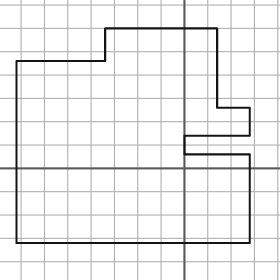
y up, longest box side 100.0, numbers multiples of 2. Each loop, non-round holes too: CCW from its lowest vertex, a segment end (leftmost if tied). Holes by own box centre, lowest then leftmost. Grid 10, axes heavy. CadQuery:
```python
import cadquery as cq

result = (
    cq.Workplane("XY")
    .moveTo(-72.0, -32.0)
    .lineTo(28.0, -32.0)
    .lineTo(28.0, 6.0)
    .lineTo(0.0, 6.0)
    .lineTo(0.0, 14.0)
    .lineTo(28.0, 14.0)
    .lineTo(28.0, 26.0)
    .lineTo(14.0, 26.0)
    .lineTo(14.0, 60.0)
    .lineTo(-34.0, 60.0)
    .lineTo(-34.0, 46.0)
    .lineTo(-72.0, 46.0)
    .close()
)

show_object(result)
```